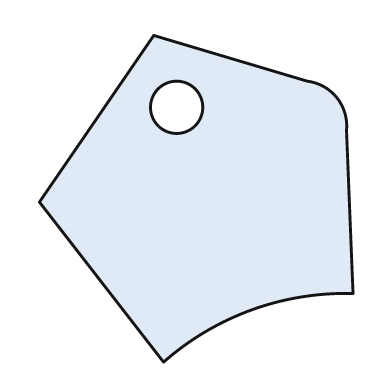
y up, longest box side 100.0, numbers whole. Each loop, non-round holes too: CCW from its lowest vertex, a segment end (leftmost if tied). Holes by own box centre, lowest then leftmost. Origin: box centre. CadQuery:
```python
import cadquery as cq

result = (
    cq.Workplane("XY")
    .moveTo(-10.0, -50.0)
    .threePointArc((17.0, -34.0), (48.0, -29.0))
    .lineTo(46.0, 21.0)
    .threePointArc((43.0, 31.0), (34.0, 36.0))
    .lineTo(-13.0, 50.0)
    .lineTo(-48.0, -1.0)
    .close()
    .moveTo(-6.0, 28.0)
    .circle(8.0)
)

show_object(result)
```